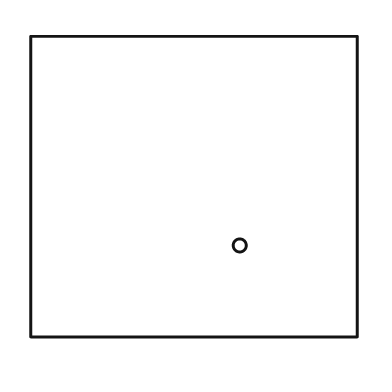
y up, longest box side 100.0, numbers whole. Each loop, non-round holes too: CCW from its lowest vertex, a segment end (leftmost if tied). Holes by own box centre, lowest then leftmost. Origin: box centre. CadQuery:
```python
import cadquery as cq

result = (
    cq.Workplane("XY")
    .moveTo(-50.0, -46.0)
    .lineTo(50.0, -46.0)
    .lineTo(50.0, 46.0)
    .lineTo(-50.0, 46.0)
    .close()
    .moveTo(14.0, -18.0)
    .circle(2.0)
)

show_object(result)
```